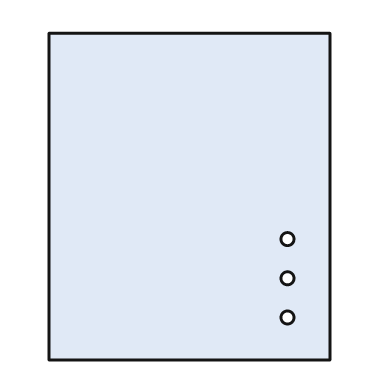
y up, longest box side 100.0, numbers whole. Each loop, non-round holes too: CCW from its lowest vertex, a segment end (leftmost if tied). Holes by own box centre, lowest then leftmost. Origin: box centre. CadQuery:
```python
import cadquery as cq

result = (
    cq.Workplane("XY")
    .moveTo(-43.0, -50.0)
    .lineTo(43.0, -50.0)
    .lineTo(43.0, 50.0)
    .lineTo(-43.0, 50.0)
    .close()
    .moveTo(30.0, -37.0)
    .circle(2.0)
    .moveTo(30.0, -25.0)
    .circle(2.0)
    .moveTo(30.0, -13.0)
    .circle(2.0)
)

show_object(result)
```